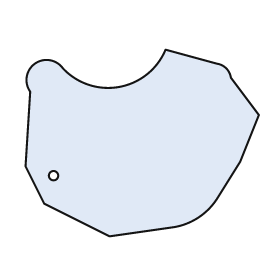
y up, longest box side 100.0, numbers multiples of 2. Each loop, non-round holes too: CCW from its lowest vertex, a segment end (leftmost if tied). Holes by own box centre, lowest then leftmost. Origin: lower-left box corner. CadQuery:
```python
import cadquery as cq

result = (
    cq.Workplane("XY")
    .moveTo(36.0, 0.0)
    .lineTo(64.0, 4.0)
    .threePointArc((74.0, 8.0), (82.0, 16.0))
    .lineTo(92.0, 32.0)
    .lineTo(100.0, 52.0)
    .lineTo(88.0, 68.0)
    .threePointArc((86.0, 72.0), (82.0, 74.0))
    .lineTo(60.0, 80.0)
    .threePointArc((40.0, 64.0), (16.0, 72.0))
    .threePointArc((4.0, 74.0), (2.0, 62.0))
    .lineTo(0.0, 30.0)
    .lineTo(8.0, 14.0)
    .close()
    .moveTo(12.0, 26.0)
    .circle(2.0)
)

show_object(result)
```